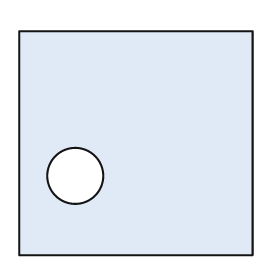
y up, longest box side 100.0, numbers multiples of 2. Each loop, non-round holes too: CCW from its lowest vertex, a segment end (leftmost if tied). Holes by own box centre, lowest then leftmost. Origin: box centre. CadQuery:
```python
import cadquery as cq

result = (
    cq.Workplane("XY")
    .moveTo(-50.0, -48.0)
    .lineTo(50.0, -48.0)
    .lineTo(50.0, 48.0)
    .lineTo(-50.0, 48.0)
    .close()
    .moveTo(-26.0, -14.0)
    .circle(12.0)
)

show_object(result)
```